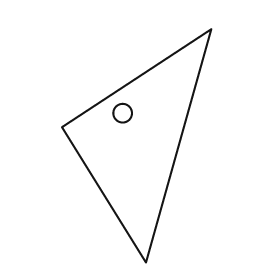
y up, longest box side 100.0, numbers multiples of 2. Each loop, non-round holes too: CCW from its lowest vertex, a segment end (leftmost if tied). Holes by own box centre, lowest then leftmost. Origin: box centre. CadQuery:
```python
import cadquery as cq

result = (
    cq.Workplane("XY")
    .moveTo(4.0, -50.0)
    .lineTo(32.0, 50.0)
    .lineTo(-32.0, 8.0)
    .close()
    .moveTo(-6.0, 14.0)
    .circle(4.0)
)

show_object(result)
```